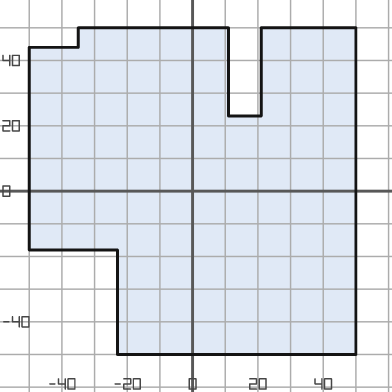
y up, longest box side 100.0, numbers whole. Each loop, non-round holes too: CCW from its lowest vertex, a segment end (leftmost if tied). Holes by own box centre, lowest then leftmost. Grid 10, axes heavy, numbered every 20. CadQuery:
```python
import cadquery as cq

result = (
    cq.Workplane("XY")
    .moveTo(-23.0, -50.0)
    .lineTo(50.0, -50.0)
    .lineTo(50.0, 50.0)
    .lineTo(21.0, 50.0)
    .lineTo(21.0, 23.0)
    .lineTo(11.0, 23.0)
    .lineTo(11.0, 50.0)
    .lineTo(-35.0, 50.0)
    .lineTo(-35.0, 44.0)
    .lineTo(-50.0, 44.0)
    .lineTo(-50.0, -18.0)
    .lineTo(-23.0, -18.0)
    .close()
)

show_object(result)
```